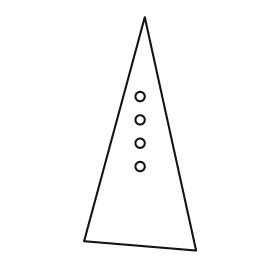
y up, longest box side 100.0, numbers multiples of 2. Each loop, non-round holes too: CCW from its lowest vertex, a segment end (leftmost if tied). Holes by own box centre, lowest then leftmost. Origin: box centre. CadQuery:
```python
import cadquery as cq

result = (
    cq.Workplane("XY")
    .moveTo(24.0, -50.0)
    .lineTo(2.0, 50.0)
    .lineTo(-24.0, -46.0)
    .close()
    .moveTo(0.0, -14.0)
    .circle(2.0)
    .moveTo(0.0, -4.0)
    .circle(2.0)
    .moveTo(0.0, 6.0)
    .circle(2.0)
    .moveTo(0.0, 16.0)
    .circle(2.0)
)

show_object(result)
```